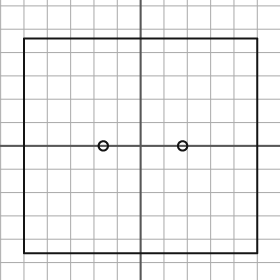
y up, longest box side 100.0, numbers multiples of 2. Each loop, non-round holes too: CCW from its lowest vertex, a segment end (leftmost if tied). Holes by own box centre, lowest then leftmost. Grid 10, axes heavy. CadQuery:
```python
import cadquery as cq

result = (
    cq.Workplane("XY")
    .moveTo(-50.0, -46.0)
    .lineTo(50.0, -46.0)
    .lineTo(50.0, 46.0)
    .lineTo(-50.0, 46.0)
    .close()
    .moveTo(-16.0, 0.0)
    .circle(2.0)
    .moveTo(18.0, 0.0)
    .circle(2.0)
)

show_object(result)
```